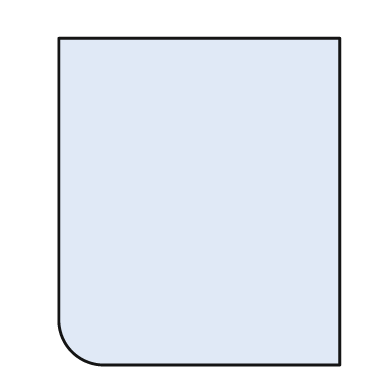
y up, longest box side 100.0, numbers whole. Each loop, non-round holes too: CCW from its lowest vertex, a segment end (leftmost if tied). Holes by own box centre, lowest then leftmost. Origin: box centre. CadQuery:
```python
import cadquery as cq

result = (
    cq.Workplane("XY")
    .moveTo(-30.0, -50.0)
    .lineTo(43.0, -50.0)
    .lineTo(43.0, 50.0)
    .lineTo(-43.0, 50.0)
    .lineTo(-43.0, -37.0)
    .threePointArc((-39.0, -46.0), (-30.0, -50.0))
    .close()
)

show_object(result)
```